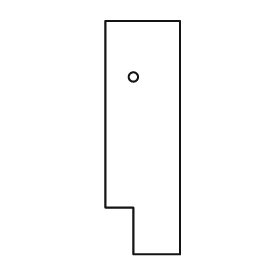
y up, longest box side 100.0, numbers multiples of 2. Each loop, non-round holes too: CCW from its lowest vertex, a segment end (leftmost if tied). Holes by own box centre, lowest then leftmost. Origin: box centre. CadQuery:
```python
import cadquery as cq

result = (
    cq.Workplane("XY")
    .moveTo(-4.0, -50.0)
    .lineTo(16.0, -50.0)
    .lineTo(16.0, 50.0)
    .lineTo(-16.0, 50.0)
    .lineTo(-16.0, -30.0)
    .lineTo(-4.0, -30.0)
    .close()
    .moveTo(-4.0, 26.0)
    .circle(2.0)
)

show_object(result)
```